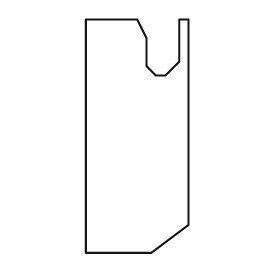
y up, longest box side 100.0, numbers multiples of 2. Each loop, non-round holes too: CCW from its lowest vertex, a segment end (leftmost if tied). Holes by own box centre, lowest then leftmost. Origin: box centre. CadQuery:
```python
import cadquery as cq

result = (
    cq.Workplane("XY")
    .moveTo(-22.0, -50.0)
    .lineTo(6.0, -50.0)
    .lineTo(22.0, -38.0)
    .lineTo(22.0, 50.0)
    .lineTo(18.0, 50.0)
    .lineTo(18.0, 32.0)
    .lineTo(12.0, 26.0)
    .lineTo(8.0, 26.0)
    .lineTo(4.0, 30.0)
    .lineTo(4.0, 42.0)
    .lineTo(0.0, 50.0)
    .lineTo(-22.0, 50.0)
    .close()
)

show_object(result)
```